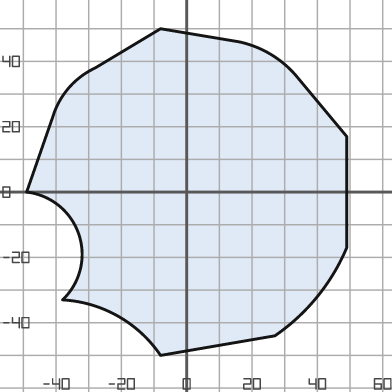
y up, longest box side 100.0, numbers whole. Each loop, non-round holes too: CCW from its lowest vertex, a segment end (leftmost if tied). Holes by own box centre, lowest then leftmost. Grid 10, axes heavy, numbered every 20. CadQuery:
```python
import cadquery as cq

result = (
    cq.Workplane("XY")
    .moveTo(-8.0, -50.0)
    .lineTo(27.0, -44.0)
    .threePointArc((40.0, -32.0), (49.0, -17.0))
    .lineTo(49.0, 17.0)
    .lineTo(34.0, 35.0)
    .threePointArc((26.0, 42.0), (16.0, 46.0))
    .lineTo(-8.0, 50.0)
    .lineTo(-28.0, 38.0)
    .threePointArc((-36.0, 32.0), (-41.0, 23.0))
    .lineTo(-49.0, 0.0)
    .threePointArc((-33.0, -13.0), (-38.0, -33.0))
    .threePointArc((-21.0, -38.0), (-8.0, -50.0))
    .close()
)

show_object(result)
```